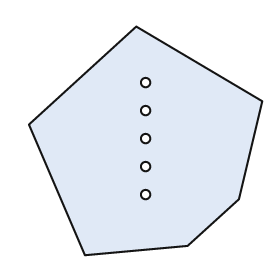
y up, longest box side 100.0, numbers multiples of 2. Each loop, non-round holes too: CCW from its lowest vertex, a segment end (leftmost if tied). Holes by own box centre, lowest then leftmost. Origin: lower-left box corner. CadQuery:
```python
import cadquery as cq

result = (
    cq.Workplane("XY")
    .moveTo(24.0, 0.0)
    .lineTo(68.0, 4.0)
    .lineTo(90.0, 24.0)
    .lineTo(100.0, 66.0)
    .lineTo(46.0, 98.0)
    .lineTo(0.0, 56.0)
    .close()
    .moveTo(50.0, 26.0)
    .circle(2.0)
    .moveTo(50.0, 38.0)
    .circle(2.0)
    .moveTo(50.0, 50.0)
    .circle(2.0)
    .moveTo(50.0, 62.0)
    .circle(2.0)
    .moveTo(50.0, 74.0)
    .circle(2.0)
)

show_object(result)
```